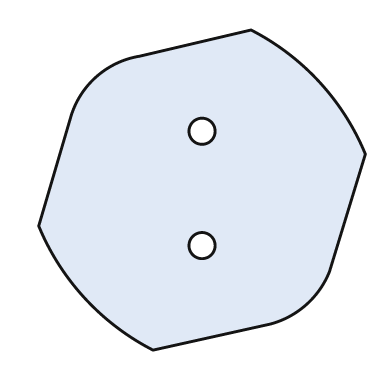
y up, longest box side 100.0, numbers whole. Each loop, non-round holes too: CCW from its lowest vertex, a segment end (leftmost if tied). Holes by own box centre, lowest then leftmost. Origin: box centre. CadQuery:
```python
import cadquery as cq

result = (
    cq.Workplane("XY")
    .moveTo(-15.0, -49.0)
    .lineTo(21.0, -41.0)
    .threePointArc((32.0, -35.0), (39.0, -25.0))
    .lineTo(50.0, 11.0)
    .threePointArc((36.0, 33.0), (15.0, 49.0))
    .lineTo(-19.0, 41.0)
    .threePointArc((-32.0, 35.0), (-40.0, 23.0))
    .lineTo(-50.0, -11.0)
    .threePointArc((-36.0, -33.0), (-15.0, -49.0))
    .close()
    .moveTo(0.0, -17.0)
    .circle(4.0)
    .moveTo(0.0, 18.0)
    .circle(4.0)
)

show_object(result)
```